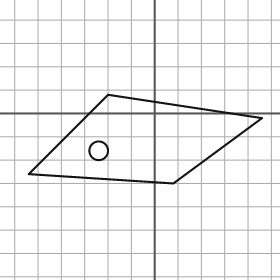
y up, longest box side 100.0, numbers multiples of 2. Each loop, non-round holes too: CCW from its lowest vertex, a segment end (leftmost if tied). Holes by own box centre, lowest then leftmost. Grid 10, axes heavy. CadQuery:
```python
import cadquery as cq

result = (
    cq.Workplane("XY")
    .moveTo(8.0, -30.0)
    .lineTo(46.0, -2.0)
    .lineTo(-20.0, 8.0)
    .lineTo(-54.0, -26.0)
    .close()
    .moveTo(-24.0, -16.0)
    .circle(4.0)
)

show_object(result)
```